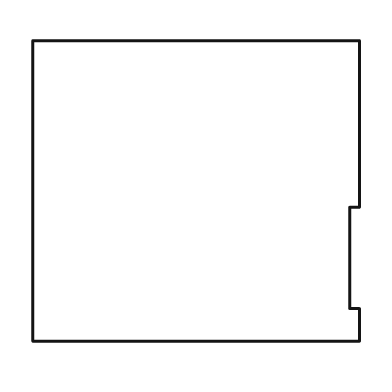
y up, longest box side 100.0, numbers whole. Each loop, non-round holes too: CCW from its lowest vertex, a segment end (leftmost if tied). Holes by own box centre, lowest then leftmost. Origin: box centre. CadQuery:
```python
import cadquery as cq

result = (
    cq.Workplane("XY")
    .moveTo(-50.0, -46.0)
    .lineTo(50.0, -46.0)
    .lineTo(50.0, -36.0)
    .lineTo(47.0, -36.0)
    .lineTo(47.0, -5.0)
    .lineTo(50.0, -5.0)
    .lineTo(50.0, 46.0)
    .lineTo(-50.0, 46.0)
    .close()
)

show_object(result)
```